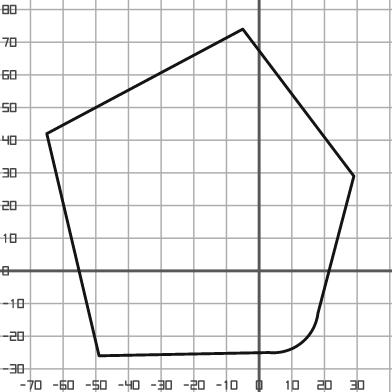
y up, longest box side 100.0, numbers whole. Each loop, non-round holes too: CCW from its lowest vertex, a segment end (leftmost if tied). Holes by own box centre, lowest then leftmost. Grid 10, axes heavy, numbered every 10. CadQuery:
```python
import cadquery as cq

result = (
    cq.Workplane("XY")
    .moveTo(-49.0, -26.0)
    .lineTo(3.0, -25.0)
    .threePointArc((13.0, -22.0), (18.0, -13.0))
    .lineTo(29.0, 29.0)
    .lineTo(-5.0, 74.0)
    .lineTo(-65.0, 42.0)
    .close()
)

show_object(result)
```